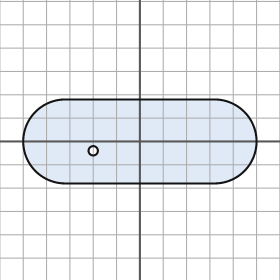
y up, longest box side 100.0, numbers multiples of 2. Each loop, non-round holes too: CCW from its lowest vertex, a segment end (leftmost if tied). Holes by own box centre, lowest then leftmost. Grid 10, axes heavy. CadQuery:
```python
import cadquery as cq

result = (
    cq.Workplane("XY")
    .moveTo(-32.0, -18.0)
    .lineTo(32.0, -18.0)
    .threePointArc((50.0, 0.0), (32.0, 18.0))
    .lineTo(-32.0, 18.0)
    .threePointArc((-50.0, 0.0), (-32.0, -18.0))
    .close()
    .moveTo(-20.0, -4.0)
    .circle(2.0)
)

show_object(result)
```